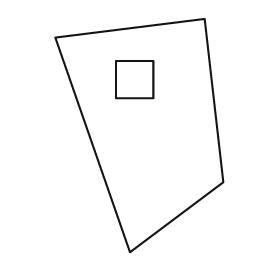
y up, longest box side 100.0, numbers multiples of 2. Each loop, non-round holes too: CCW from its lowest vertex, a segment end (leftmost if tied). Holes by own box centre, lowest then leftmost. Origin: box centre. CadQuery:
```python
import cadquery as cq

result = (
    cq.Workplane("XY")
    .moveTo(-4.0, -50.0)
    .lineTo(36.0, -20.0)
    .lineTo(28.0, 50.0)
    .lineTo(-36.0, 42.0)
    .close()
    .moveTo(-10.0, 16.0)
    .lineTo(6.0, 16.0)
    .lineTo(6.0, 32.0)
    .lineTo(-10.0, 32.0)
    .close()
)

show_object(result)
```